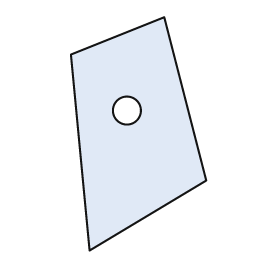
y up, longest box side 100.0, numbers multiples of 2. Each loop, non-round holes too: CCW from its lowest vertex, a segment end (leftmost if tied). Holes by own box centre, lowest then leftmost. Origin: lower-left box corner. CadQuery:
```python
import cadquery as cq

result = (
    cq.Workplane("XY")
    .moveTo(8.0, 0.0)
    .lineTo(58.0, 30.0)
    .lineTo(40.0, 100.0)
    .lineTo(0.0, 84.0)
    .close()
    .moveTo(24.0, 60.0)
    .circle(6.0)
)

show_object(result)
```